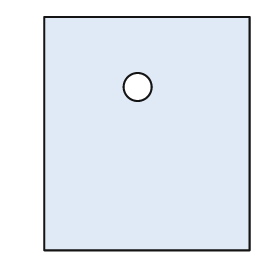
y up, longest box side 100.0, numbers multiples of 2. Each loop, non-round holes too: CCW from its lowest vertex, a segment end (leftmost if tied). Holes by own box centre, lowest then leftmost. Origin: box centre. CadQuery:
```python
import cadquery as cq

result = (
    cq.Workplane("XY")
    .moveTo(-44.0, -50.0)
    .lineTo(44.0, -50.0)
    .lineTo(44.0, 50.0)
    .lineTo(-44.0, 50.0)
    .close()
    .moveTo(-4.0, 20.0)
    .circle(6.0)
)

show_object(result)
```